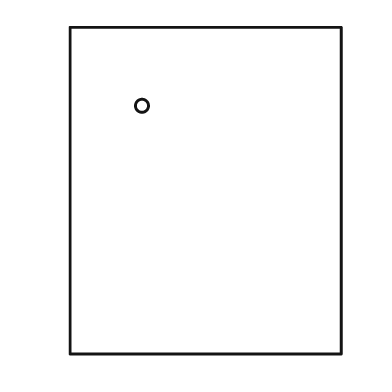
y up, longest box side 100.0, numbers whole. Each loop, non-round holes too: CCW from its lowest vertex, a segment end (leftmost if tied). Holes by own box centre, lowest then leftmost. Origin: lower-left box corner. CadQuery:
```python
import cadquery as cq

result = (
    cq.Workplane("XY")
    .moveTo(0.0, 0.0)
    .lineTo(83.0, 0.0)
    .lineTo(83.0, 100.0)
    .lineTo(0.0, 100.0)
    .close()
    .moveTo(22.0, 76.0)
    .circle(2.0)
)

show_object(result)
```